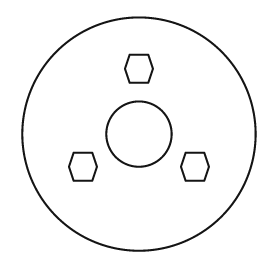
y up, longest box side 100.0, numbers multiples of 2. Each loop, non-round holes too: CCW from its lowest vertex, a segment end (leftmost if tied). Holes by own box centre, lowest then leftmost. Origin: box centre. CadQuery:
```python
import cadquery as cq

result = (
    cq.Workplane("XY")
    .moveTo(0.0, 0.0)
    .circle(50.0)
    .moveTo(-28.0, -20.0)
    .lineTo(-20.0, -20.0)
    .lineTo(-18.0, -14.0)
    .lineTo(-20.0, -8.0)
    .lineTo(-28.0, -8.0)
    .lineTo(-30.0, -14.0)
    .close()
    .moveTo(20.0, -20.0)
    .lineTo(28.0, -20.0)
    .lineTo(30.0, -14.0)
    .lineTo(28.0, -8.0)
    .lineTo(20.0, -8.0)
    .lineTo(18.0, -14.0)
    .close()
    .moveTo(0.0, 0.0)
    .circle(14.0)
    .moveTo(-4.0, 22.0)
    .lineTo(4.0, 22.0)
    .lineTo(6.0, 28.0)
    .lineTo(4.0, 34.0)
    .lineTo(-4.0, 34.0)
    .lineTo(-6.0, 28.0)
    .close()
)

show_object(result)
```